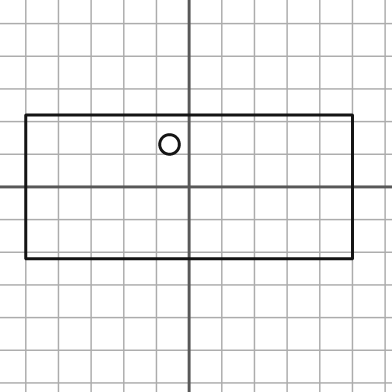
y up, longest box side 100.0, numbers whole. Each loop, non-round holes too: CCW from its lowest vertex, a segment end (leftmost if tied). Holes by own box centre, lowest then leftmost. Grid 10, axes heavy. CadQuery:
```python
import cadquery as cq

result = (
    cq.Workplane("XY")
    .moveTo(-50.0, -22.0)
    .lineTo(50.0, -22.0)
    .lineTo(50.0, 22.0)
    .lineTo(-50.0, 22.0)
    .close()
    .moveTo(-6.0, 13.0)
    .circle(3.0)
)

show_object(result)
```